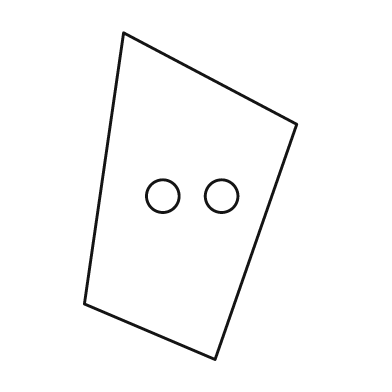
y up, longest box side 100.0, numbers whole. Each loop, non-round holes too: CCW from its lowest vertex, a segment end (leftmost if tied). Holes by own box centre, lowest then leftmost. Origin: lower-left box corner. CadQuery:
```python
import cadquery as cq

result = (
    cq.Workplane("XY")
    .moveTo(40.0, 0.0)
    .lineTo(65.0, 72.0)
    .lineTo(12.0, 100.0)
    .lineTo(0.0, 17.0)
    .close()
    .moveTo(24.0, 50.0)
    .circle(5.0)
    .moveTo(42.0, 50.0)
    .circle(5.0)
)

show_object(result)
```